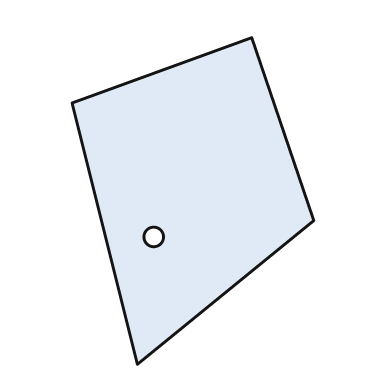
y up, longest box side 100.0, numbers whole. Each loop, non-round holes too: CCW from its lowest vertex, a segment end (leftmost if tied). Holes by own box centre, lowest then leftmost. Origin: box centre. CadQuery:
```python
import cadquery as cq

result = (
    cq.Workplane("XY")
    .moveTo(-17.0, -50.0)
    .lineTo(37.0, -6.0)
    .lineTo(18.0, 50.0)
    .lineTo(-37.0, 30.0)
    .close()
    .moveTo(-12.0, -11.0)
    .circle(3.0)
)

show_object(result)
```